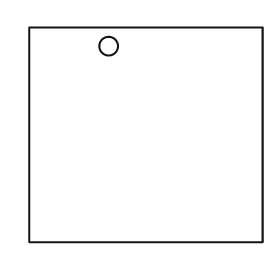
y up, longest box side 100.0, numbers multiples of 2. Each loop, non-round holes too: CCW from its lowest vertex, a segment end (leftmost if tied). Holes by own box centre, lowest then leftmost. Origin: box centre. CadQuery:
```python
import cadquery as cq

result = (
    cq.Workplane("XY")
    .moveTo(-50.0, -46.0)
    .lineTo(50.0, -46.0)
    .lineTo(50.0, 46.0)
    .lineTo(-50.0, 46.0)
    .close()
    .moveTo(-16.0, 38.0)
    .circle(4.0)
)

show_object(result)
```